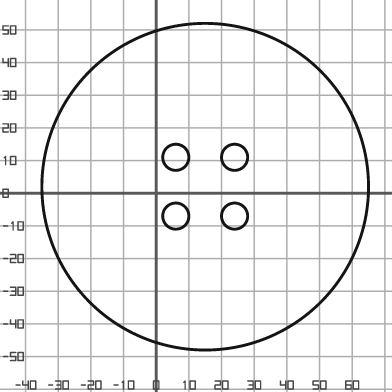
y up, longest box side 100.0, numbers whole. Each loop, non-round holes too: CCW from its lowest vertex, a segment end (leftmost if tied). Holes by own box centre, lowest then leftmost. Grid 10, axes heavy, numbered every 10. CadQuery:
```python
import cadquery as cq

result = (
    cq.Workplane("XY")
    .moveTo(15.0, 2.0)
    .circle(50.0)
    .moveTo(6.0, -7.0)
    .circle(4.0)
    .moveTo(24.0, -7.0)
    .circle(4.0)
    .moveTo(6.0, 11.0)
    .circle(4.0)
    .moveTo(24.0, 11.0)
    .circle(4.0)
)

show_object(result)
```